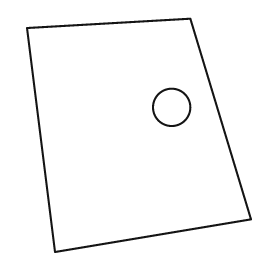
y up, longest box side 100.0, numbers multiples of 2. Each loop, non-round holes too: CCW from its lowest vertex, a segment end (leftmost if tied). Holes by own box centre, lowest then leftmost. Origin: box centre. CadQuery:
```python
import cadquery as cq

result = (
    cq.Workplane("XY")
    .moveTo(-36.0, -50.0)
    .lineTo(48.0, -36.0)
    .lineTo(22.0, 50.0)
    .lineTo(-48.0, 46.0)
    .close()
    .moveTo(14.0, 12.0)
    .circle(8.0)
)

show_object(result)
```